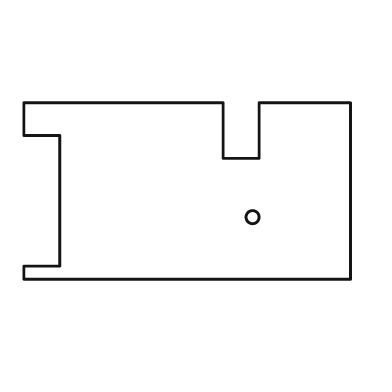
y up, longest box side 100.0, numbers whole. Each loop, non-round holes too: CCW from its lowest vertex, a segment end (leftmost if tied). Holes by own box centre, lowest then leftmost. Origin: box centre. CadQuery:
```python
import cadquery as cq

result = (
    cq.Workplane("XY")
    .moveTo(-50.0, -27.0)
    .lineTo(50.0, -27.0)
    .lineTo(50.0, 27.0)
    .lineTo(22.0, 27.0)
    .lineTo(22.0, 10.0)
    .lineTo(11.0, 10.0)
    .lineTo(11.0, 27.0)
    .lineTo(-50.0, 27.0)
    .lineTo(-50.0, 17.0)
    .lineTo(-39.0, 17.0)
    .lineTo(-39.0, -23.0)
    .lineTo(-50.0, -23.0)
    .close()
    .moveTo(20.0, -8.0)
    .circle(2.0)
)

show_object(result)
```